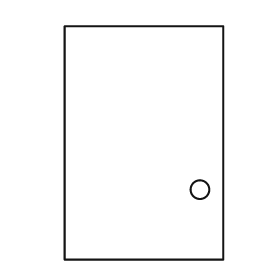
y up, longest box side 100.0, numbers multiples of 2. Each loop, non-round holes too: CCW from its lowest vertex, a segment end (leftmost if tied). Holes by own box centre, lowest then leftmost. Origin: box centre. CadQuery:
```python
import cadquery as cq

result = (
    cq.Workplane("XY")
    .moveTo(-34.0, -50.0)
    .lineTo(34.0, -50.0)
    .lineTo(34.0, 50.0)
    .lineTo(-34.0, 50.0)
    .close()
    .moveTo(24.0, -20.0)
    .circle(4.0)
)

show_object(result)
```